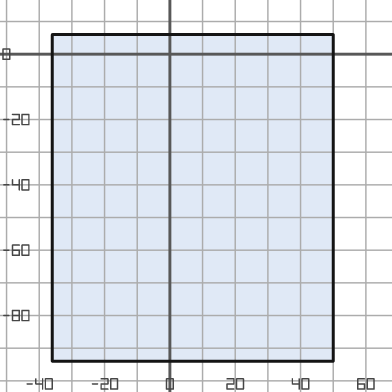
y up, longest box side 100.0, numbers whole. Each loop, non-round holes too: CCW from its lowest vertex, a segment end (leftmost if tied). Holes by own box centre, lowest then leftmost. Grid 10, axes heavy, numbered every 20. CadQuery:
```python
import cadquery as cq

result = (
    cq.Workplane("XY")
    .moveTo(-36.0, -94.0)
    .lineTo(50.0, -94.0)
    .lineTo(50.0, 6.0)
    .lineTo(-36.0, 6.0)
    .close()
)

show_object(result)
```